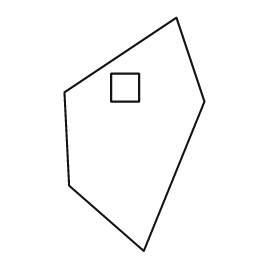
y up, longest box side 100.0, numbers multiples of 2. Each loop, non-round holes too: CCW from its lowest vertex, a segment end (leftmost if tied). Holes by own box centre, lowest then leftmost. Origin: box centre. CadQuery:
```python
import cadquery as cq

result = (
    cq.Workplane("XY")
    .moveTo(4.0, -50.0)
    .lineTo(30.0, 14.0)
    .lineTo(18.0, 50.0)
    .lineTo(-30.0, 18.0)
    .lineTo(-28.0, -22.0)
    .close()
    .moveTo(-10.0, 14.0)
    .lineTo(2.0, 14.0)
    .lineTo(2.0, 26.0)
    .lineTo(-10.0, 26.0)
    .close()
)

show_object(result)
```